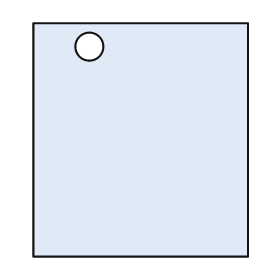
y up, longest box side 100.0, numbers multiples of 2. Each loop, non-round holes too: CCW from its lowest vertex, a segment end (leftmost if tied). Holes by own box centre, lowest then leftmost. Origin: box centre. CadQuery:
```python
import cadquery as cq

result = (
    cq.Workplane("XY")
    .moveTo(-46.0, -50.0)
    .lineTo(46.0, -50.0)
    .lineTo(46.0, 50.0)
    .lineTo(-46.0, 50.0)
    .close()
    .moveTo(-22.0, 40.0)
    .circle(6.0)
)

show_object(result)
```